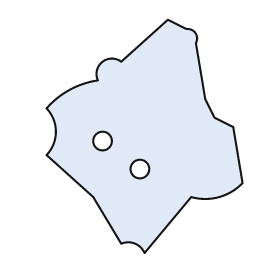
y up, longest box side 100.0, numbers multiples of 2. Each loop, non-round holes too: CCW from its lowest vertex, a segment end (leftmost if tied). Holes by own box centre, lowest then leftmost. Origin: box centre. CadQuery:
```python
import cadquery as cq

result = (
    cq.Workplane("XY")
    .moveTo(0.0, -50.0)
    .lineTo(20.0, -26.0)
    .threePointArc((32.0, -26.0), (42.0, -20.0))
    .lineTo(38.0, 4.0)
    .lineTo(30.0, 8.0)
    .lineTo(26.0, 16.0)
    .lineTo(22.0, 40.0)
    .threePointArc((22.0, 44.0), (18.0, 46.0))
    .lineTo(10.0, 50.0)
    .lineTo(-10.0, 32.0)
    .threePointArc((-18.0, 32.0), (-20.0, 24.0))
    .threePointArc((-32.0, 20.0), (-42.0, 12.0))
    .threePointArc((-38.0, 2.0), (-42.0, -8.0))
    .lineTo(-22.0, -26.0)
    .lineTo(-10.0, -46.0)
    .threePointArc((-4.0, -46.0), (0.0, -50.0))
    .close()
    .moveTo(-2.0, -14.0)
    .circle(4.0)
    .moveTo(-18.0, -2.0)
    .circle(4.0)
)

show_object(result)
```